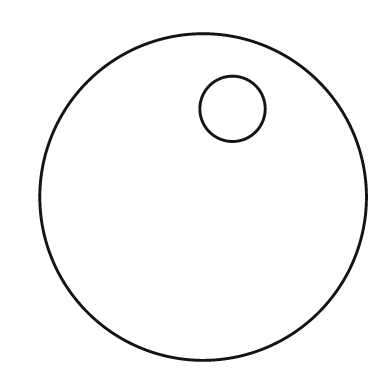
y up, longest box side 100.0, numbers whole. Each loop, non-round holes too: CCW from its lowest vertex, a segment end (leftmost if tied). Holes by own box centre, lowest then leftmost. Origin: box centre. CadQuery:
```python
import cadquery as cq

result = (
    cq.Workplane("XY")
    .moveTo(0.0, 0.0)
    .circle(50.0)
    .moveTo(9.0, 27.0)
    .circle(10.0)
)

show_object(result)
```